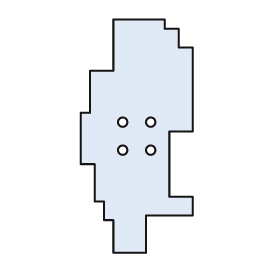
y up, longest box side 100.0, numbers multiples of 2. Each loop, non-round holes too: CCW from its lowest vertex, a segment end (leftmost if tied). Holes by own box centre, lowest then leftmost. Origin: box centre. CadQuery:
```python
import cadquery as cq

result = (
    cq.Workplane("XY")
    .moveTo(-10.0, -50.0)
    .lineTo(4.0, -50.0)
    .lineTo(4.0, -34.0)
    .lineTo(24.0, -34.0)
    .lineTo(24.0, -26.0)
    .lineTo(14.0, -26.0)
    .lineTo(14.0, 2.0)
    .lineTo(24.0, 2.0)
    .lineTo(24.0, 38.0)
    .lineTo(18.0, 38.0)
    .lineTo(18.0, 46.0)
    .lineTo(12.0, 46.0)
    .lineTo(12.0, 50.0)
    .lineTo(-10.0, 50.0)
    .lineTo(-10.0, 28.0)
    .lineTo(-20.0, 28.0)
    .lineTo(-20.0, 10.0)
    .lineTo(-24.0, 10.0)
    .lineTo(-24.0, -12.0)
    .lineTo(-18.0, -12.0)
    .lineTo(-18.0, -28.0)
    .lineTo(-14.0, -28.0)
    .lineTo(-14.0, -36.0)
    .lineTo(-10.0, -36.0)
    .close()
    .moveTo(-6.0, -6.0)
    .circle(2.0)
    .moveTo(6.0, -6.0)
    .circle(2.0)
    .moveTo(-6.0, 6.0)
    .circle(2.0)
    .moveTo(6.0, 6.0)
    .circle(2.0)
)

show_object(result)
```